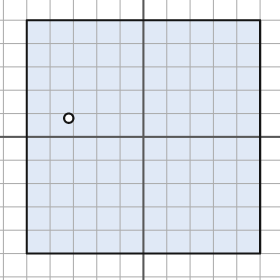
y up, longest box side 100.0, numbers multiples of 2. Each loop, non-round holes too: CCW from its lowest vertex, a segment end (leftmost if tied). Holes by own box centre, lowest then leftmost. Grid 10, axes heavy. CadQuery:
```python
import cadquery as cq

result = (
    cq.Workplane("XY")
    .moveTo(-50.0, -50.0)
    .lineTo(50.0, -50.0)
    .lineTo(50.0, 50.0)
    .lineTo(-50.0, 50.0)
    .close()
    .moveTo(-32.0, 8.0)
    .circle(2.0)
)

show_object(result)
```